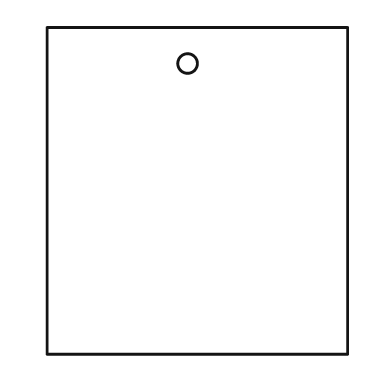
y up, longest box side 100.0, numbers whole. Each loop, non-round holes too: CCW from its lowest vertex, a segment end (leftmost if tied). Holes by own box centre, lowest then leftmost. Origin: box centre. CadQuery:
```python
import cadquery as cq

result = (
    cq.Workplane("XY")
    .moveTo(-46.0, -50.0)
    .lineTo(46.0, -50.0)
    .lineTo(46.0, 50.0)
    .lineTo(-46.0, 50.0)
    .close()
    .moveTo(-3.0, 39.0)
    .circle(3.0)
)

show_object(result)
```